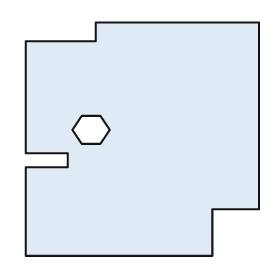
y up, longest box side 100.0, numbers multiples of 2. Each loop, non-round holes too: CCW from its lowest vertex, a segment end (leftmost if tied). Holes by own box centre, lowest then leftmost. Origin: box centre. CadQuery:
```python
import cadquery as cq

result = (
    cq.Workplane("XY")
    .moveTo(-50.0, -50.0)
    .lineTo(30.0, -50.0)
    .lineTo(30.0, -30.0)
    .lineTo(50.0, -30.0)
    .lineTo(50.0, 50.0)
    .lineTo(-20.0, 50.0)
    .lineTo(-20.0, 42.0)
    .lineTo(-50.0, 42.0)
    .lineTo(-50.0, -6.0)
    .lineTo(-32.0, -6.0)
    .lineTo(-32.0, -12.0)
    .lineTo(-50.0, -12.0)
    .close()
    .moveTo(-26.0, -2.0)
    .lineTo(-18.0, -2.0)
    .lineTo(-14.0, 4.0)
    .lineTo(-18.0, 10.0)
    .lineTo(-26.0, 10.0)
    .lineTo(-30.0, 4.0)
    .close()
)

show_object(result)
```